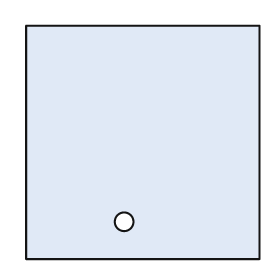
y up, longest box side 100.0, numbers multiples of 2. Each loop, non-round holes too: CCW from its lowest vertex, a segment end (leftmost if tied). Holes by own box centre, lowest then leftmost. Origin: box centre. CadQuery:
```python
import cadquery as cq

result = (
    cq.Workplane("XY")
    .moveTo(-50.0, -50.0)
    .lineTo(50.0, -50.0)
    .lineTo(50.0, 50.0)
    .lineTo(-50.0, 50.0)
    .close()
    .moveTo(-8.0, -34.0)
    .circle(4.0)
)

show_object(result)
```